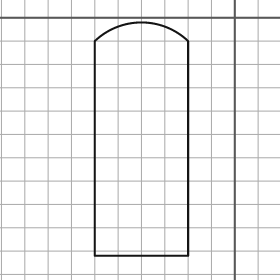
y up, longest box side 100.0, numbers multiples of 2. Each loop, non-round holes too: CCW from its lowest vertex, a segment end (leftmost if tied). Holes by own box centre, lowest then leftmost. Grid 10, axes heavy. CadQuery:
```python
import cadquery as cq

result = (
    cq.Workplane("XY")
    .moveTo(-60.0, -102.0)
    .lineTo(-20.0, -102.0)
    .lineTo(-20.0, -10.0)
    .threePointArc((-40.0, -2.0), (-60.0, -10.0))
    .close()
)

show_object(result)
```